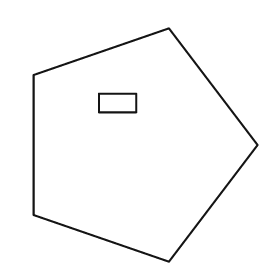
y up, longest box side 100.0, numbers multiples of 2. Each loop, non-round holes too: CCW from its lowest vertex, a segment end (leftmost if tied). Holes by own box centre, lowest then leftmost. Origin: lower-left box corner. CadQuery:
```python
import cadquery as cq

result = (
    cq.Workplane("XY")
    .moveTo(58.0, 0.0)
    .lineTo(96.0, 50.0)
    .lineTo(58.0, 100.0)
    .lineTo(0.0, 80.0)
    .lineTo(0.0, 20.0)
    .close()
    .moveTo(28.0, 64.0)
    .lineTo(44.0, 64.0)
    .lineTo(44.0, 72.0)
    .lineTo(28.0, 72.0)
    .close()
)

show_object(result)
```